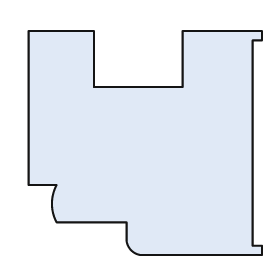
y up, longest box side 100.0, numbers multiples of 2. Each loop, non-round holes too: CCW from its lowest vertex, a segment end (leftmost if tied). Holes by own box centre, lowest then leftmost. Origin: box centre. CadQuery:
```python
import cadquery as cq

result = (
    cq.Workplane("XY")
    .moveTo(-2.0, -48.0)
    .lineTo(50.0, -48.0)
    .lineTo(50.0, -44.0)
    .lineTo(46.0, -44.0)
    .lineTo(46.0, 44.0)
    .lineTo(50.0, 44.0)
    .lineTo(50.0, 48.0)
    .lineTo(16.0, 48.0)
    .lineTo(16.0, 24.0)
    .lineTo(-22.0, 24.0)
    .lineTo(-22.0, 48.0)
    .lineTo(-50.0, 48.0)
    .lineTo(-50.0, -18.0)
    .lineTo(-38.0, -18.0)
    .threePointArc((-40.0, -26.0), (-38.0, -34.0))
    .lineTo(-8.0, -34.0)
    .lineTo(-8.0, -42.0)
    .threePointArc((-6.0, -46.0), (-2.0, -48.0))
    .close()
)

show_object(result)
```